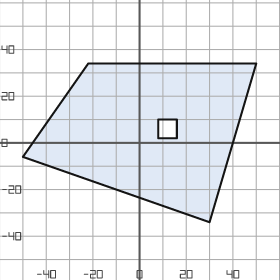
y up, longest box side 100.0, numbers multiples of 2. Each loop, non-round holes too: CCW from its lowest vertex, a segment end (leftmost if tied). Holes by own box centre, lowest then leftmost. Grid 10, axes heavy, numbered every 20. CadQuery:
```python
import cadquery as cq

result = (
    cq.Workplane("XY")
    .moveTo(30.0, -34.0)
    .lineTo(50.0, 34.0)
    .lineTo(-22.0, 34.0)
    .lineTo(-50.0, -6.0)
    .close()
    .moveTo(8.0, 2.0)
    .lineTo(16.0, 2.0)
    .lineTo(16.0, 10.0)
    .lineTo(8.0, 10.0)
    .close()
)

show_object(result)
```